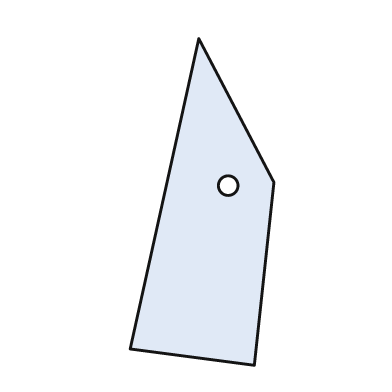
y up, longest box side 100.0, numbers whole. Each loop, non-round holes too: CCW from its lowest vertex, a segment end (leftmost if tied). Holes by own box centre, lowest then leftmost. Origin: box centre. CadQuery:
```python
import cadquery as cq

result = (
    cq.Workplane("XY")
    .moveTo(16.0, -50.0)
    .lineTo(22.0, 6.0)
    .lineTo(-1.0, 50.0)
    .lineTo(-22.0, -45.0)
    .close()
    .moveTo(8.0, 5.0)
    .circle(3.0)
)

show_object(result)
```